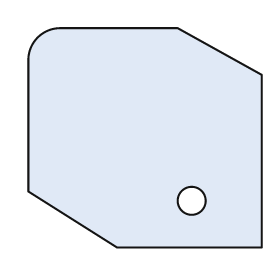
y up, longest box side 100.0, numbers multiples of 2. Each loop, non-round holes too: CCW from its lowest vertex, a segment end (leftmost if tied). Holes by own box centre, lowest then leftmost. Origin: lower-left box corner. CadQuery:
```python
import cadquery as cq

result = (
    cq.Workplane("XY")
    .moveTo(38.0, 0.0)
    .lineTo(100.0, 0.0)
    .lineTo(100.0, 74.0)
    .lineTo(64.0, 94.0)
    .lineTo(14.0, 94.0)
    .threePointArc((4.0, 90.0), (0.0, 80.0))
    .lineTo(0.0, 24.0)
    .close()
    .moveTo(70.0, 20.0)
    .circle(6.0)
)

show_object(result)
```